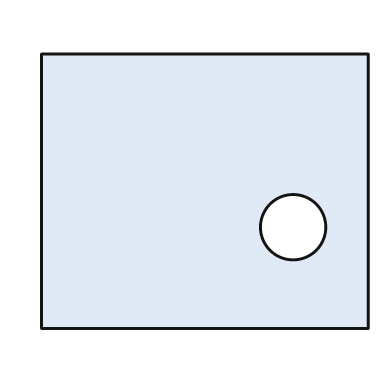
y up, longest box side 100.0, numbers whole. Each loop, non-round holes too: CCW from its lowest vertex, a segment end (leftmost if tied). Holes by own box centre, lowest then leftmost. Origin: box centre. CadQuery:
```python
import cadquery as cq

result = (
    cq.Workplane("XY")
    .moveTo(-50.0, -42.0)
    .lineTo(50.0, -42.0)
    .lineTo(50.0, 42.0)
    .lineTo(-50.0, 42.0)
    .close()
    .moveTo(27.0, -11.0)
    .circle(10.0)
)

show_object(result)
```